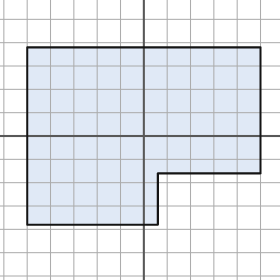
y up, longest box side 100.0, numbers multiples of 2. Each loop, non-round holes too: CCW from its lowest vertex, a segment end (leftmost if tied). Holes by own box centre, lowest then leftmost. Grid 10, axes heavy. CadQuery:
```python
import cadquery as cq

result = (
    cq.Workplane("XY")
    .moveTo(-50.0, -38.0)
    .lineTo(6.0, -38.0)
    .lineTo(6.0, -16.0)
    .lineTo(50.0, -16.0)
    .lineTo(50.0, 38.0)
    .lineTo(-50.0, 38.0)
    .close()
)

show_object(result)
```